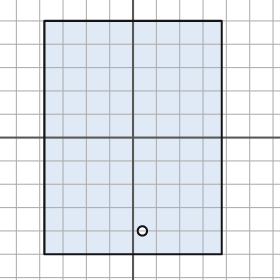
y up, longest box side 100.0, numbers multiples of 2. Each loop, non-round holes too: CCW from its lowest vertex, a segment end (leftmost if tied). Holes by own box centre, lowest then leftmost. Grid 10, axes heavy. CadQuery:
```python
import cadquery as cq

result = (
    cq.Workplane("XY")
    .moveTo(-38.0, -50.0)
    .lineTo(38.0, -50.0)
    .lineTo(38.0, 50.0)
    .lineTo(-38.0, 50.0)
    .close()
    .moveTo(4.0, -40.0)
    .circle(2.0)
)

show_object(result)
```